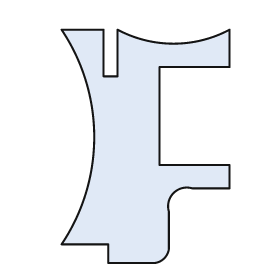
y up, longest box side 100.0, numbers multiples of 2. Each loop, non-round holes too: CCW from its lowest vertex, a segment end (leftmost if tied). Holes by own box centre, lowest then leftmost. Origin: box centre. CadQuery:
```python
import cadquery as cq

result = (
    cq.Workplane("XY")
    .moveTo(-16.0, -50.0)
    .lineTo(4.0, -50.0)
    .threePointArc((8.0, -48.0), (10.0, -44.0))
    .lineTo(10.0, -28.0)
    .threePointArc((12.0, -20.0), (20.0, -18.0))
    .lineTo(36.0, -18.0)
    .lineTo(36.0, -8.0)
    .lineTo(6.0, -8.0)
    .lineTo(6.0, 34.0)
    .lineTo(36.0, 34.0)
    .lineTo(36.0, 50.0)
    .threePointArc((12.0, 44.0), (-12.0, 50.0))
    .lineTo(-12.0, 30.0)
    .lineTo(-18.0, 30.0)
    .lineTo(-18.0, 50.0)
    .lineTo(-36.0, 50.0)
    .threePointArc((-22.0, 4.0), (-36.0, -42.0))
    .lineTo(-16.0, -42.0)
    .close()
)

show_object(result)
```